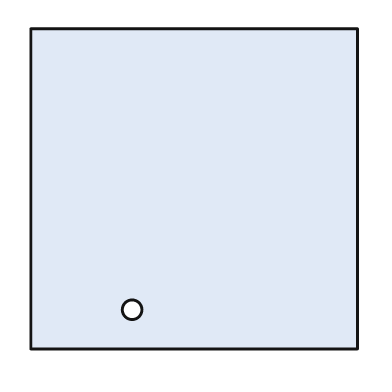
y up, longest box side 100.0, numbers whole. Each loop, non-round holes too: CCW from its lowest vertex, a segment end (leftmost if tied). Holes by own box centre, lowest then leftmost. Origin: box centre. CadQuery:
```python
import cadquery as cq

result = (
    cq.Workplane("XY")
    .moveTo(-50.0, -49.0)
    .lineTo(50.0, -49.0)
    .lineTo(50.0, 49.0)
    .lineTo(-50.0, 49.0)
    .close()
    .moveTo(-19.0, -37.0)
    .circle(3.0)
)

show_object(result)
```